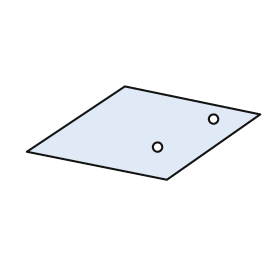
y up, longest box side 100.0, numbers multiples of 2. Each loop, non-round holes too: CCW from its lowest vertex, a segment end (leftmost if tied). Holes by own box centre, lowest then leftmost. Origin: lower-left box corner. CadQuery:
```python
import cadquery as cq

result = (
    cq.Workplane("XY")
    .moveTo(60.0, 0.0)
    .lineTo(100.0, 28.0)
    .lineTo(42.0, 40.0)
    .lineTo(0.0, 12.0)
    .close()
    .moveTo(56.0, 14.0)
    .circle(2.0)
    .moveTo(80.0, 26.0)
    .circle(2.0)
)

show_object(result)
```